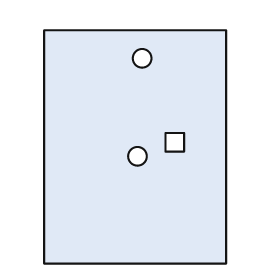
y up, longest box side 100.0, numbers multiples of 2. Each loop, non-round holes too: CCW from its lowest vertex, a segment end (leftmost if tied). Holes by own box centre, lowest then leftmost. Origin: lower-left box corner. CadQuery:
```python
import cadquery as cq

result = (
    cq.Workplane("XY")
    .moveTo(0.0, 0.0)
    .lineTo(78.0, 0.0)
    .lineTo(78.0, 100.0)
    .lineTo(0.0, 100.0)
    .close()
    .moveTo(40.0, 46.0)
    .circle(4.0)
    .moveTo(52.0, 48.0)
    .lineTo(60.0, 48.0)
    .lineTo(60.0, 56.0)
    .lineTo(52.0, 56.0)
    .close()
    .moveTo(42.0, 88.0)
    .circle(4.0)
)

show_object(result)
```